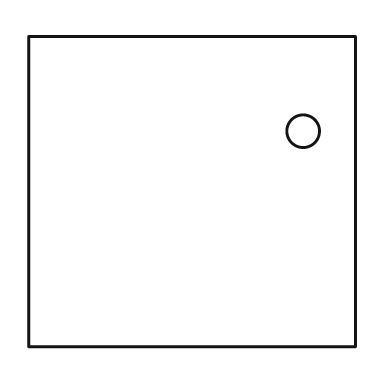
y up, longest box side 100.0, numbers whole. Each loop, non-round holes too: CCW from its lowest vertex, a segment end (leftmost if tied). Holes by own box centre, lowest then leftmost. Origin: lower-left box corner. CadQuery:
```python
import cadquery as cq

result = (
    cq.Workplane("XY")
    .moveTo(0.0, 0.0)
    .lineTo(100.0, 0.0)
    .lineTo(100.0, 95.0)
    .lineTo(0.0, 95.0)
    .close()
    .moveTo(84.0, 66.0)
    .circle(5.0)
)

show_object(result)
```